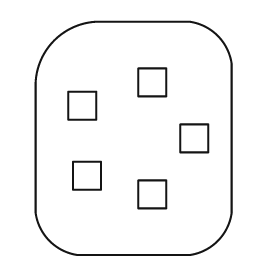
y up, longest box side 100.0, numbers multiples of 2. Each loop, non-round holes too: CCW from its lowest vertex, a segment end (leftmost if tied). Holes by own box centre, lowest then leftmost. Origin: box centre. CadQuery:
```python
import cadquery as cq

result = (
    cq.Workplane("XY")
    .moveTo(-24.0, -50.0)
    .lineTo(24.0, -50.0)
    .threePointArc((36.0, -44.0), (42.0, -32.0))
    .lineTo(42.0, 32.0)
    .threePointArc((36.0, 44.0), (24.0, 50.0))
    .lineTo(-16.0, 50.0)
    .threePointArc((-34.0, 42.0), (-42.0, 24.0))
    .lineTo(-42.0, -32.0)
    .threePointArc((-36.0, -44.0), (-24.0, -50.0))
    .close()
    .moveTo(2.0, -30.0)
    .lineTo(14.0, -30.0)
    .lineTo(14.0, -18.0)
    .lineTo(2.0, -18.0)
    .close()
    .moveTo(-26.0, -22.0)
    .lineTo(-14.0, -22.0)
    .lineTo(-14.0, -10.0)
    .lineTo(-26.0, -10.0)
    .close()
    .moveTo(20.0, -6.0)
    .lineTo(32.0, -6.0)
    .lineTo(32.0, 6.0)
    .lineTo(20.0, 6.0)
    .close()
    .moveTo(-28.0, 8.0)
    .lineTo(-16.0, 8.0)
    .lineTo(-16.0, 20.0)
    .lineTo(-28.0, 20.0)
    .close()
    .moveTo(2.0, 18.0)
    .lineTo(14.0, 18.0)
    .lineTo(14.0, 30.0)
    .lineTo(2.0, 30.0)
    .close()
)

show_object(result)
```